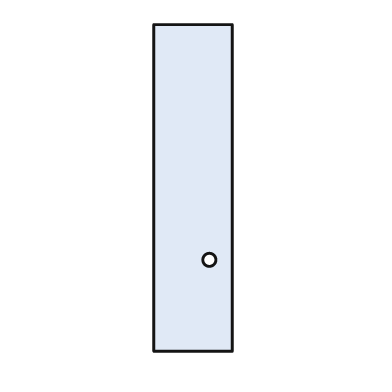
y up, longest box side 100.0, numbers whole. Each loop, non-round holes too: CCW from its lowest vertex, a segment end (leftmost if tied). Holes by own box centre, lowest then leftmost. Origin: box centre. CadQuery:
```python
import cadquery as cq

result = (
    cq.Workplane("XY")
    .moveTo(-12.0, -50.0)
    .lineTo(12.0, -50.0)
    .lineTo(12.0, 50.0)
    .lineTo(-12.0, 50.0)
    .close()
    .moveTo(5.0, -22.0)
    .circle(2.0)
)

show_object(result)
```